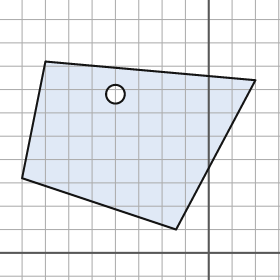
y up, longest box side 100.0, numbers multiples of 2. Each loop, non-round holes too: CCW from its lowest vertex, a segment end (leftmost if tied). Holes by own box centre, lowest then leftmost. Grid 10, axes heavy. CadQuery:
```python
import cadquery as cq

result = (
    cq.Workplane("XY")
    .moveTo(-14.0, 10.0)
    .lineTo(20.0, 74.0)
    .lineTo(-70.0, 82.0)
    .lineTo(-80.0, 32.0)
    .close()
    .moveTo(-40.0, 68.0)
    .circle(4.0)
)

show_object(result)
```